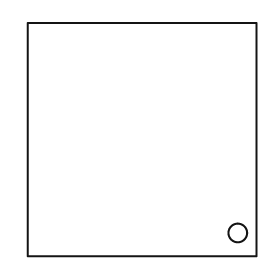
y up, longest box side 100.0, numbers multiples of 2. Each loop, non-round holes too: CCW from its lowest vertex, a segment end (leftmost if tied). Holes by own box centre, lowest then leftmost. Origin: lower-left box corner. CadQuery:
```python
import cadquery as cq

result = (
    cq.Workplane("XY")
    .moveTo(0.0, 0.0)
    .lineTo(98.0, 0.0)
    .lineTo(98.0, 100.0)
    .lineTo(0.0, 100.0)
    .close()
    .moveTo(90.0, 10.0)
    .circle(4.0)
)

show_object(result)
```